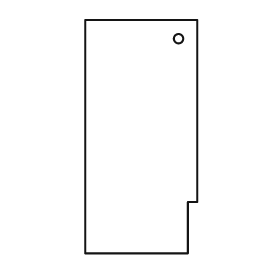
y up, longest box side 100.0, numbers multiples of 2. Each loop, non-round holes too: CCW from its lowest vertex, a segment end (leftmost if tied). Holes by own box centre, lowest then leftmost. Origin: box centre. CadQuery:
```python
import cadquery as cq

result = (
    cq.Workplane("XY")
    .moveTo(-24.0, -50.0)
    .lineTo(20.0, -50.0)
    .lineTo(20.0, -28.0)
    .lineTo(24.0, -28.0)
    .lineTo(24.0, 50.0)
    .lineTo(-24.0, 50.0)
    .close()
    .moveTo(16.0, 42.0)
    .circle(2.0)
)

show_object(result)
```